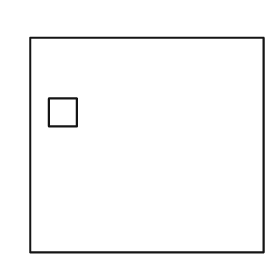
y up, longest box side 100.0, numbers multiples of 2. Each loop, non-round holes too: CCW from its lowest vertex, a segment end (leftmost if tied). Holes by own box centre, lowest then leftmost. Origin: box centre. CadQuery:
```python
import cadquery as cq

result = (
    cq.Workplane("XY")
    .moveTo(-50.0, -46.0)
    .lineTo(50.0, -46.0)
    .lineTo(50.0, 46.0)
    .lineTo(-50.0, 46.0)
    .close()
    .moveTo(-42.0, 8.0)
    .lineTo(-30.0, 8.0)
    .lineTo(-30.0, 20.0)
    .lineTo(-42.0, 20.0)
    .close()
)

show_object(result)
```